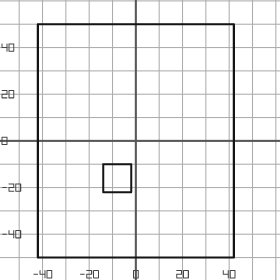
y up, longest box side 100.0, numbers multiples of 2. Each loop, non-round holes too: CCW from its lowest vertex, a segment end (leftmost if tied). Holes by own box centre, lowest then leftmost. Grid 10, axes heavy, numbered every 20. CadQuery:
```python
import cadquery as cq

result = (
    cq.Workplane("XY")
    .moveTo(-42.0, -50.0)
    .lineTo(42.0, -50.0)
    .lineTo(42.0, 50.0)
    .lineTo(-42.0, 50.0)
    .close()
    .moveTo(-14.0, -22.0)
    .lineTo(-2.0, -22.0)
    .lineTo(-2.0, -10.0)
    .lineTo(-14.0, -10.0)
    .close()
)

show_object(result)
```